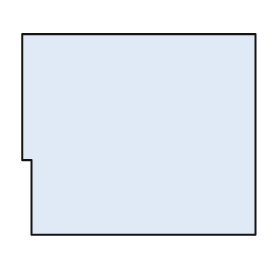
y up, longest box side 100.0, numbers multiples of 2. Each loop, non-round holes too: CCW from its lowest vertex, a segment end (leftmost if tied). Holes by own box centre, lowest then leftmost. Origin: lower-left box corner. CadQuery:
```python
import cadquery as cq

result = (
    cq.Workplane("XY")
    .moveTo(4.0, 0.0)
    .lineTo(100.0, 0.0)
    .lineTo(100.0, 86.0)
    .lineTo(0.0, 86.0)
    .lineTo(0.0, 32.0)
    .lineTo(4.0, 32.0)
    .close()
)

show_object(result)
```